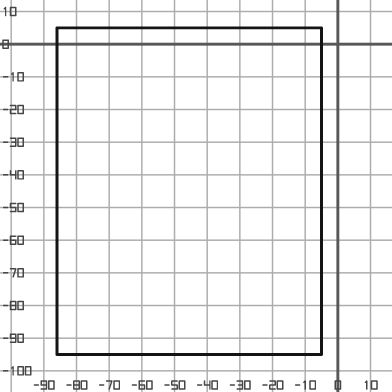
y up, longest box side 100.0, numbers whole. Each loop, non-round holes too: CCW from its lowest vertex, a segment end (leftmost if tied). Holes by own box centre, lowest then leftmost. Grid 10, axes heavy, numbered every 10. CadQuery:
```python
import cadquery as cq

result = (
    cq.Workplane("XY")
    .moveTo(-86.0, -95.0)
    .lineTo(-5.0, -95.0)
    .lineTo(-5.0, 5.0)
    .lineTo(-86.0, 5.0)
    .close()
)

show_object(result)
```